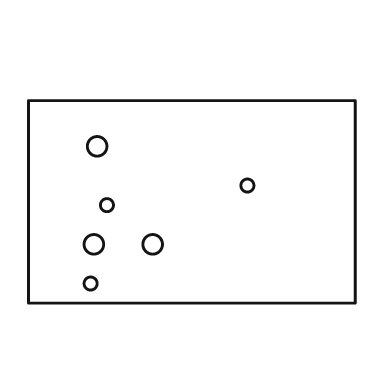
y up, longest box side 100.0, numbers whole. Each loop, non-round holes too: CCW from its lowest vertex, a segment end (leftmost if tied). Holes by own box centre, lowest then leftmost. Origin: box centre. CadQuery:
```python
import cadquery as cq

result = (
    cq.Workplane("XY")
    .moveTo(-50.0, -31.0)
    .lineTo(50.0, -31.0)
    .lineTo(50.0, 31.0)
    .lineTo(-50.0, 31.0)
    .close()
    .moveTo(-31.0, -25.0)
    .circle(2.0)
    .moveTo(-30.0, -13.0)
    .circle(3.0)
    .moveTo(-12.0, -13.0)
    .circle(3.0)
    .moveTo(-26.0, -1.0)
    .circle(2.0)
    .moveTo(17.0, 5.0)
    .circle(2.0)
    .moveTo(-29.0, 17.0)
    .circle(3.0)
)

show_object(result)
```